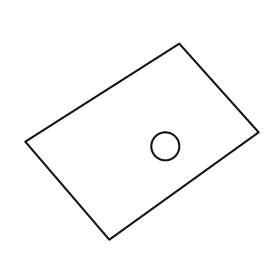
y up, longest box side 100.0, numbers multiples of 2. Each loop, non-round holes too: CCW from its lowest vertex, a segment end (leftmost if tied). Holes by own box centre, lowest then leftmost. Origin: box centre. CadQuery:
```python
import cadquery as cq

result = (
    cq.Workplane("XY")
    .moveTo(-14.0, -42.0)
    .lineTo(50.0, 4.0)
    .lineTo(16.0, 42.0)
    .lineTo(-50.0, 0.0)
    .close()
    .moveTo(10.0, -2.0)
    .circle(6.0)
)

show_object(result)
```